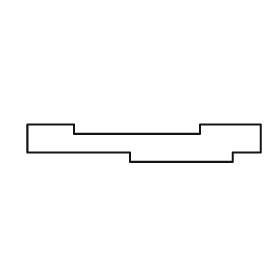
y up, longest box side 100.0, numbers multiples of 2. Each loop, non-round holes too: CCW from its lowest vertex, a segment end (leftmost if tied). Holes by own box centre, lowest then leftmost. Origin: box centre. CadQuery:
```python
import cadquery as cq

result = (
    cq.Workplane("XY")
    .moveTo(-6.0, -8.0)
    .lineTo(38.0, -8.0)
    .lineTo(38.0, -4.0)
    .lineTo(50.0, -4.0)
    .lineTo(50.0, 8.0)
    .lineTo(24.0, 8.0)
    .lineTo(24.0, 4.0)
    .lineTo(-30.0, 4.0)
    .lineTo(-30.0, 8.0)
    .lineTo(-50.0, 8.0)
    .lineTo(-50.0, -4.0)
    .lineTo(-6.0, -4.0)
    .close()
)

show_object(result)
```